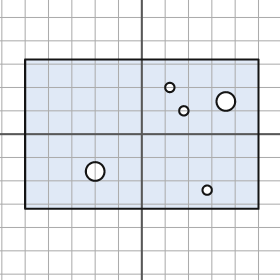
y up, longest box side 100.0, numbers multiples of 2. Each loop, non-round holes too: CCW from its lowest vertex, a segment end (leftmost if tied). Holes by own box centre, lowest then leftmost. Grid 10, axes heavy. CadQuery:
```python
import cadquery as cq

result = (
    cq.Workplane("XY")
    .moveTo(-50.0, -32.0)
    .lineTo(50.0, -32.0)
    .lineTo(50.0, 32.0)
    .lineTo(-50.0, 32.0)
    .close()
    .moveTo(28.0, -24.0)
    .circle(2.0)
    .moveTo(-20.0, -16.0)
    .circle(4.0)
    .moveTo(18.0, 10.0)
    .circle(2.0)
    .moveTo(36.0, 14.0)
    .circle(4.0)
    .moveTo(12.0, 20.0)
    .circle(2.0)
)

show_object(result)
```